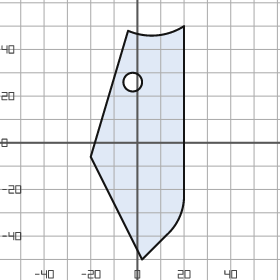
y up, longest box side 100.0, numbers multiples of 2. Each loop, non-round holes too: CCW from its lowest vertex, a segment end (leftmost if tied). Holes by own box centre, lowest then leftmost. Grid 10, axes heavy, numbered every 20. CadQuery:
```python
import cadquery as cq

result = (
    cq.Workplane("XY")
    .moveTo(2.0, -50.0)
    .lineTo(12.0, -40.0)
    .threePointArc((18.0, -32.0), (20.0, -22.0))
    .lineTo(20.0, 50.0)
    .threePointArc((8.0, 46.0), (-4.0, 48.0))
    .lineTo(-20.0, -6.0)
    .close()
    .moveTo(-2.0, 26.0)
    .circle(4.0)
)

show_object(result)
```